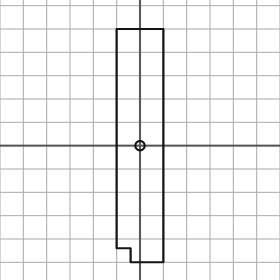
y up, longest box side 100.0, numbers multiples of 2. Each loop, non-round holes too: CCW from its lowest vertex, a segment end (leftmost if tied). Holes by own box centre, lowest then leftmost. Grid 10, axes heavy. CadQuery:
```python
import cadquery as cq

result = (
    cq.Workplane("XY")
    .moveTo(-4.0, -50.0)
    .lineTo(10.0, -50.0)
    .lineTo(10.0, 50.0)
    .lineTo(-10.0, 50.0)
    .lineTo(-10.0, -44.0)
    .lineTo(-4.0, -44.0)
    .close()
    .moveTo(0.0, 0.0)
    .circle(2.0)
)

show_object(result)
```